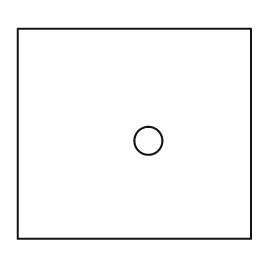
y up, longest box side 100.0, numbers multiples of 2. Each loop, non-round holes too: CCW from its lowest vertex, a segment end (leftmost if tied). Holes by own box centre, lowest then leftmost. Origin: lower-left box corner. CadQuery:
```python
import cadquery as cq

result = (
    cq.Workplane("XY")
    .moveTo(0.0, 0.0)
    .lineTo(100.0, 0.0)
    .lineTo(100.0, 90.0)
    .lineTo(0.0, 90.0)
    .close()
    .moveTo(56.0, 42.0)
    .circle(6.0)
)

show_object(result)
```